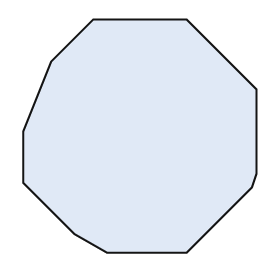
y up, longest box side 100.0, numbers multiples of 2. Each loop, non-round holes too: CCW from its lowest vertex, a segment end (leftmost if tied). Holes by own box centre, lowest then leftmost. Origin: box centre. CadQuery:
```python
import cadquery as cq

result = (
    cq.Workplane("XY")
    .moveTo(-14.0, -50.0)
    .lineTo(20.0, -50.0)
    .lineTo(48.0, -22.0)
    .lineTo(50.0, -16.0)
    .lineTo(50.0, 20.0)
    .lineTo(20.0, 50.0)
    .lineTo(-20.0, 50.0)
    .lineTo(-38.0, 32.0)
    .lineTo(-50.0, 2.0)
    .lineTo(-50.0, -20.0)
    .lineTo(-28.0, -42.0)
    .close()
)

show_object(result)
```